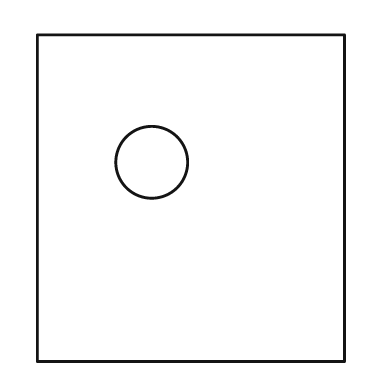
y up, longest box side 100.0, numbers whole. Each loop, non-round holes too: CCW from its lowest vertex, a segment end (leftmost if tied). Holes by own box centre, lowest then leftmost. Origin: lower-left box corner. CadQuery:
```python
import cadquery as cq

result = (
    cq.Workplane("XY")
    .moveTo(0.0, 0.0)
    .lineTo(94.0, 0.0)
    .lineTo(94.0, 100.0)
    .lineTo(0.0, 100.0)
    .close()
    .moveTo(35.0, 61.0)
    .circle(11.0)
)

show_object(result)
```